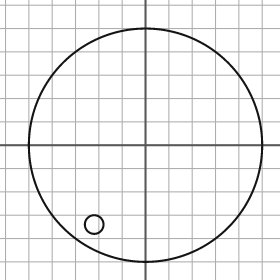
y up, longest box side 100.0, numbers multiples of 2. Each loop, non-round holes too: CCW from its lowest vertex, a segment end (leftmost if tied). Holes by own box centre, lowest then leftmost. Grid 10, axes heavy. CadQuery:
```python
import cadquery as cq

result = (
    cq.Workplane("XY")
    .moveTo(0.0, 0.0)
    .circle(50.0)
    .moveTo(-22.0, -34.0)
    .circle(4.0)
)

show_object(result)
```